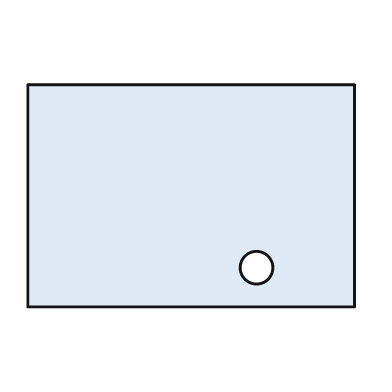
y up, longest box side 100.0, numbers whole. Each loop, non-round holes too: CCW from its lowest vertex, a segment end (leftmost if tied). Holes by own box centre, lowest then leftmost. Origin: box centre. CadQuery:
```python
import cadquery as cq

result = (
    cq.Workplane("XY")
    .moveTo(-50.0, -34.0)
    .lineTo(50.0, -34.0)
    .lineTo(50.0, 34.0)
    .lineTo(-50.0, 34.0)
    .close()
    .moveTo(20.0, -22.0)
    .circle(5.0)
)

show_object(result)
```